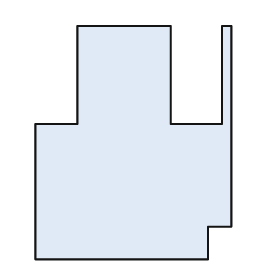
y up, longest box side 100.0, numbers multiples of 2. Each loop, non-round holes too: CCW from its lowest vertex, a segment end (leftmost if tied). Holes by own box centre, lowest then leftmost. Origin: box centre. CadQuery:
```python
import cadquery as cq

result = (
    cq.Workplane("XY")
    .moveTo(-42.0, -50.0)
    .lineTo(32.0, -50.0)
    .lineTo(32.0, -36.0)
    .lineTo(42.0, -36.0)
    .lineTo(42.0, 50.0)
    .lineTo(38.0, 50.0)
    .lineTo(38.0, 8.0)
    .lineTo(16.0, 8.0)
    .lineTo(16.0, 50.0)
    .lineTo(-24.0, 50.0)
    .lineTo(-24.0, 8.0)
    .lineTo(-42.0, 8.0)
    .close()
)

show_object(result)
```